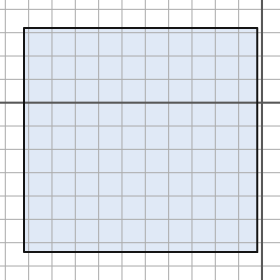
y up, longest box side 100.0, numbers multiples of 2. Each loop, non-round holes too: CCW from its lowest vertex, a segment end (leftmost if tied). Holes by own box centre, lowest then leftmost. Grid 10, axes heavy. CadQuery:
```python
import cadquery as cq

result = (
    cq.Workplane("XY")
    .moveTo(-102.0, -64.0)
    .lineTo(-2.0, -64.0)
    .lineTo(-2.0, 32.0)
    .lineTo(-102.0, 32.0)
    .close()
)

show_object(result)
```